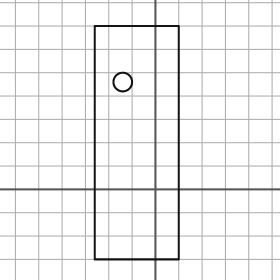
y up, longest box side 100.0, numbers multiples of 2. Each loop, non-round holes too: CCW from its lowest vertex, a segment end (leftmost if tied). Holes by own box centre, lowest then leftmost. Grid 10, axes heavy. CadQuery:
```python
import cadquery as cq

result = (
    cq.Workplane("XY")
    .moveTo(-26.0, -30.0)
    .lineTo(10.0, -30.0)
    .lineTo(10.0, 70.0)
    .lineTo(-26.0, 70.0)
    .close()
    .moveTo(-14.0, 46.0)
    .circle(4.0)
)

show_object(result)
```